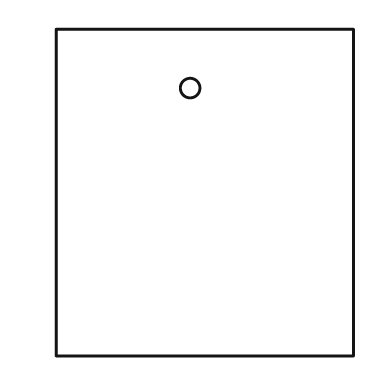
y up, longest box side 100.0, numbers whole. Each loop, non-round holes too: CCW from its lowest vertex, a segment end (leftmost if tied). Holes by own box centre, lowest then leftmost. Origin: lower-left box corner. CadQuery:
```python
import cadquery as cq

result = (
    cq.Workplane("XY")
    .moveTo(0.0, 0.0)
    .lineTo(91.0, 0.0)
    .lineTo(91.0, 100.0)
    .lineTo(0.0, 100.0)
    .close()
    .moveTo(41.0, 82.0)
    .circle(3.0)
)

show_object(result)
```